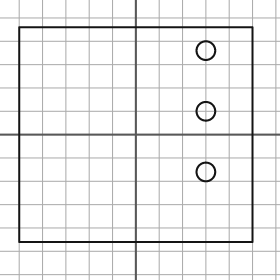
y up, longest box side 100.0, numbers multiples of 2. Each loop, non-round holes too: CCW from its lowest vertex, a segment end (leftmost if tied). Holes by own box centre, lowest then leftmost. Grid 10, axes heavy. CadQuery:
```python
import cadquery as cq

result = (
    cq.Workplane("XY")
    .moveTo(-50.0, -46.0)
    .lineTo(50.0, -46.0)
    .lineTo(50.0, 46.0)
    .lineTo(-50.0, 46.0)
    .close()
    .moveTo(30.0, -16.0)
    .circle(4.0)
    .moveTo(30.0, 10.0)
    .circle(4.0)
    .moveTo(30.0, 36.0)
    .circle(4.0)
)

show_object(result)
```